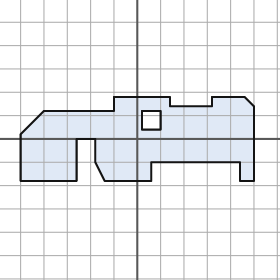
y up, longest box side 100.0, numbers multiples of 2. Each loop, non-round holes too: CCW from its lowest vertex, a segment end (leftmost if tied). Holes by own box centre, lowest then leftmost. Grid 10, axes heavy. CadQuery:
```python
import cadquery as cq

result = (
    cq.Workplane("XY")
    .moveTo(-50.0, -18.0)
    .lineTo(-26.0, -18.0)
    .lineTo(-26.0, 0.0)
    .lineTo(-18.0, 0.0)
    .lineTo(-18.0, -10.0)
    .lineTo(-14.0, -18.0)
    .lineTo(6.0, -18.0)
    .lineTo(6.0, -10.0)
    .lineTo(44.0, -10.0)
    .lineTo(44.0, -18.0)
    .lineTo(50.0, -18.0)
    .lineTo(50.0, 14.0)
    .lineTo(46.0, 18.0)
    .lineTo(32.0, 18.0)
    .lineTo(32.0, 14.0)
    .lineTo(14.0, 14.0)
    .lineTo(14.0, 18.0)
    .lineTo(-10.0, 18.0)
    .lineTo(-10.0, 12.0)
    .lineTo(-40.0, 12.0)
    .lineTo(-50.0, 2.0)
    .close()
    .moveTo(2.0, 4.0)
    .lineTo(10.0, 4.0)
    .lineTo(10.0, 12.0)
    .lineTo(2.0, 12.0)
    .close()
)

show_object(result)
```